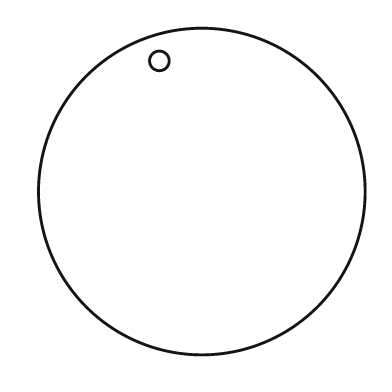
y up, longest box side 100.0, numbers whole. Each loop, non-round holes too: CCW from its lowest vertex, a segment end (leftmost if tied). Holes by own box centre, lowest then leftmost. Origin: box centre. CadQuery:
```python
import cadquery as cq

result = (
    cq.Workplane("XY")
    .moveTo(0.0, 0.0)
    .circle(50.0)
    .moveTo(-13.0, 40.0)
    .circle(3.0)
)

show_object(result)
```